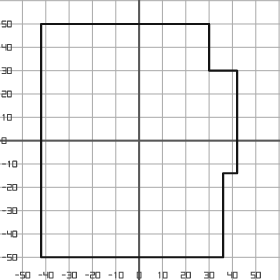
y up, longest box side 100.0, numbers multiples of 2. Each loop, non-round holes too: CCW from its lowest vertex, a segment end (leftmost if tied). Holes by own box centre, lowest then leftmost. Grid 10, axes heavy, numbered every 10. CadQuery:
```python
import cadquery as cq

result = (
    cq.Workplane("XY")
    .moveTo(-42.0, -50.0)
    .lineTo(36.0, -50.0)
    .lineTo(36.0, -14.0)
    .lineTo(42.0, -14.0)
    .lineTo(42.0, 30.0)
    .lineTo(30.0, 30.0)
    .lineTo(30.0, 50.0)
    .lineTo(-42.0, 50.0)
    .close()
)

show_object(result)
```